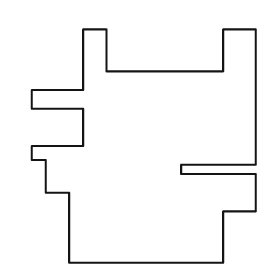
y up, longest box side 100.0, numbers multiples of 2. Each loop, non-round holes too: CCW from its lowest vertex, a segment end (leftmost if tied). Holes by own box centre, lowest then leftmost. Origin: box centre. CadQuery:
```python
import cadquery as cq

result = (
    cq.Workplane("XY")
    .moveTo(-32.0, -50.0)
    .lineTo(34.0, -50.0)
    .lineTo(34.0, -28.0)
    .lineTo(48.0, -28.0)
    .lineTo(48.0, -12.0)
    .lineTo(16.0, -12.0)
    .lineTo(16.0, -8.0)
    .lineTo(48.0, -8.0)
    .lineTo(48.0, 50.0)
    .lineTo(34.0, 50.0)
    .lineTo(34.0, 32.0)
    .lineTo(-16.0, 32.0)
    .lineTo(-16.0, 50.0)
    .lineTo(-26.0, 50.0)
    .lineTo(-26.0, 24.0)
    .lineTo(-48.0, 24.0)
    .lineTo(-48.0, 16.0)
    .lineTo(-26.0, 16.0)
    .lineTo(-26.0, 0.0)
    .lineTo(-48.0, 0.0)
    .lineTo(-48.0, -6.0)
    .lineTo(-42.0, -6.0)
    .lineTo(-42.0, -20.0)
    .lineTo(-32.0, -20.0)
    .close()
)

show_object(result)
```